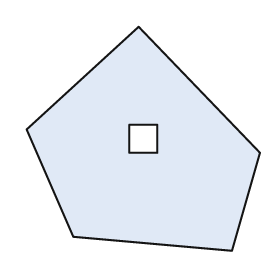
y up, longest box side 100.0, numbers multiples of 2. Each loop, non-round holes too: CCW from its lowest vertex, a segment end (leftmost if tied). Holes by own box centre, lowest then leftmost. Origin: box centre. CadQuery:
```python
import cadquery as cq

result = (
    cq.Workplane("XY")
    .moveTo(38.0, -48.0)
    .lineTo(50.0, -6.0)
    .lineTo(-2.0, 48.0)
    .lineTo(-50.0, 4.0)
    .lineTo(-30.0, -42.0)
    .close()
    .moveTo(-6.0, -6.0)
    .lineTo(6.0, -6.0)
    .lineTo(6.0, 6.0)
    .lineTo(-6.0, 6.0)
    .close()
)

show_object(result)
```